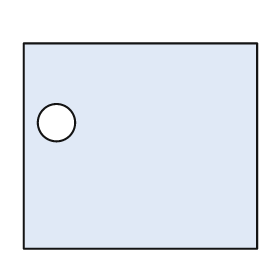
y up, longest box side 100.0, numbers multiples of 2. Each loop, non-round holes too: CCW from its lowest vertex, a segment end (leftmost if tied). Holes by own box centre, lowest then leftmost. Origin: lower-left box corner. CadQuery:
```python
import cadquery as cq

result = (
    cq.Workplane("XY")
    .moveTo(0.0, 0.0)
    .lineTo(100.0, 0.0)
    .lineTo(100.0, 88.0)
    .lineTo(0.0, 88.0)
    .close()
    .moveTo(14.0, 54.0)
    .circle(8.0)
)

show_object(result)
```